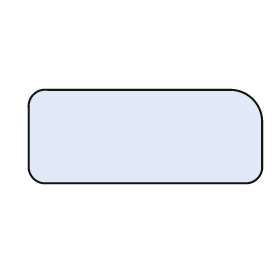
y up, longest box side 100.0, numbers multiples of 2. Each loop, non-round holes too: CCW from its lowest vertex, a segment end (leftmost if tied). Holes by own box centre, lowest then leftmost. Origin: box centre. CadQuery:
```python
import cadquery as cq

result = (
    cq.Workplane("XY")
    .moveTo(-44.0, -20.0)
    .lineTo(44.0, -20.0)
    .threePointArc((48.0, -18.0), (50.0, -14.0))
    .lineTo(50.0, 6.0)
    .threePointArc((46.0, 16.0), (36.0, 20.0))
    .lineTo(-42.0, 20.0)
    .threePointArc((-48.0, 18.0), (-50.0, 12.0))
    .lineTo(-50.0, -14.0)
    .threePointArc((-48.0, -18.0), (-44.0, -20.0))
    .close()
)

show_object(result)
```